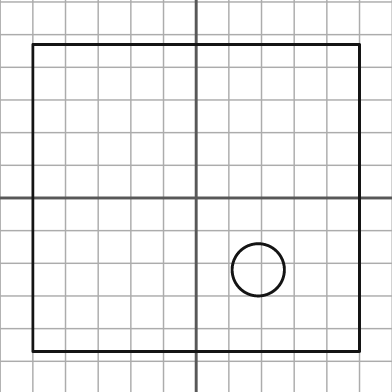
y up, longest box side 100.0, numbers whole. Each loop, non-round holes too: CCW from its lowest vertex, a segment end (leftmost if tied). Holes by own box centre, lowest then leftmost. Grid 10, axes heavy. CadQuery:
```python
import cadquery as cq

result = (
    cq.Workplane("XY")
    .moveTo(-50.0, -47.0)
    .lineTo(50.0, -47.0)
    .lineTo(50.0, 47.0)
    .lineTo(-50.0, 47.0)
    .close()
    .moveTo(19.0, -22.0)
    .circle(8.0)
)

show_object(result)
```